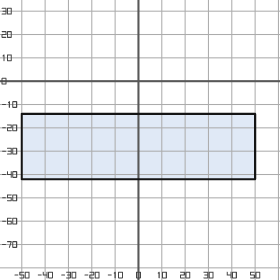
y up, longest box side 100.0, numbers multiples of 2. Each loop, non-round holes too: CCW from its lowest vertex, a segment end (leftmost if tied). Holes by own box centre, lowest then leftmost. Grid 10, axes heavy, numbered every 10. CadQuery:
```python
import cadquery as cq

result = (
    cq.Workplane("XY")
    .moveTo(-50.0, -42.0)
    .lineTo(50.0, -42.0)
    .lineTo(50.0, -14.0)
    .lineTo(-50.0, -14.0)
    .close()
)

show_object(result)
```